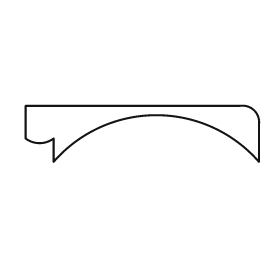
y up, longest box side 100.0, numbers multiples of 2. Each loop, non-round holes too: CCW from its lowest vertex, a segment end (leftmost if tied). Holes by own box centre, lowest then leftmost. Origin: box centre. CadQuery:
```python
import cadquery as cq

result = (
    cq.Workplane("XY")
    .moveTo(-38.0, -12.0)
    .threePointArc((6.0, 8.0), (50.0, -12.0))
    .lineTo(50.0, 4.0)
    .threePointArc((48.0, 10.0), (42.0, 12.0))
    .lineTo(-50.0, 12.0)
    .lineTo(-50.0, -2.0)
    .threePointArc((-44.0, -4.0), (-38.0, -2.0))
    .close()
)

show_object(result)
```